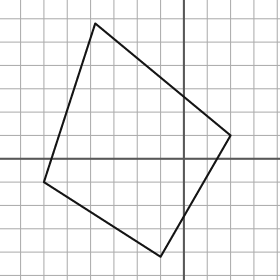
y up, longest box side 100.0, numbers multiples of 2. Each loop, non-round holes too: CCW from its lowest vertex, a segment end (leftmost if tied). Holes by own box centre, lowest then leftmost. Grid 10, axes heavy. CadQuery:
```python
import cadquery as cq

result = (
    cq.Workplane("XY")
    .moveTo(-10.0, -42.0)
    .lineTo(20.0, 10.0)
    .lineTo(-38.0, 58.0)
    .lineTo(-60.0, -10.0)
    .close()
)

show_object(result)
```